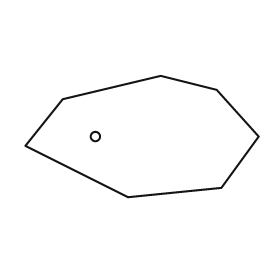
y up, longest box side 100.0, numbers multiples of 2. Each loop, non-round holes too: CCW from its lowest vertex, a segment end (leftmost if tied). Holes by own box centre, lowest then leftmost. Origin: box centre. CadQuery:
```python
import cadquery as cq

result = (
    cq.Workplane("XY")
    .moveTo(-6.0, -26.0)
    .lineTo(34.0, -22.0)
    .lineTo(50.0, 0.0)
    .lineTo(32.0, 20.0)
    .lineTo(8.0, 26.0)
    .lineTo(-34.0, 16.0)
    .lineTo(-50.0, -4.0)
    .close()
    .moveTo(-20.0, 0.0)
    .circle(2.0)
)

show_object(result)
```